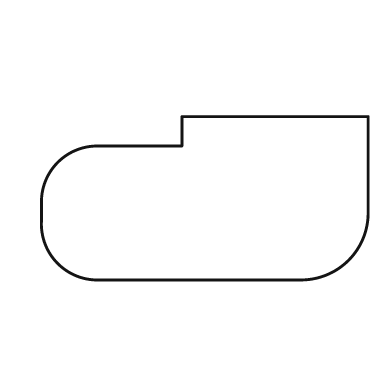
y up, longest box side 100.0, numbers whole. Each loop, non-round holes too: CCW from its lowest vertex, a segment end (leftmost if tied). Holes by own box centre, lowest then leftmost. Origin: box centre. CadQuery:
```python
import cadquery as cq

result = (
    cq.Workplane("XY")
    .moveTo(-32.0, -25.0)
    .lineTo(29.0, -25.0)
    .threePointArc((44.0, -19.0), (50.0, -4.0))
    .lineTo(50.0, 25.0)
    .lineTo(-7.0, 25.0)
    .lineTo(-7.0, 16.0)
    .lineTo(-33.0, 16.0)
    .threePointArc((-45.0, 11.0), (-50.0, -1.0))
    .lineTo(-50.0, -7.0)
    .threePointArc((-45.0, -20.0), (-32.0, -25.0))
    .close()
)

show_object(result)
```